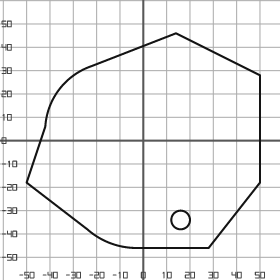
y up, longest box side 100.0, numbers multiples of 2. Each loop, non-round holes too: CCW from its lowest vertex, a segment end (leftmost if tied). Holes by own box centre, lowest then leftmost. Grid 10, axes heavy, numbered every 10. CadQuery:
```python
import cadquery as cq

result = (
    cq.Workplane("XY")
    .moveTo(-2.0, -46.0)
    .lineTo(28.0, -46.0)
    .lineTo(50.0, -18.0)
    .lineTo(50.0, 28.0)
    .lineTo(14.0, 46.0)
    .lineTo(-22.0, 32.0)
    .threePointArc((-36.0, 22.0), (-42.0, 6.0))
    .lineTo(-50.0, -18.0)
    .lineTo(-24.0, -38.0)
    .threePointArc((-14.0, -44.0), (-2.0, -46.0))
    .close()
    .moveTo(16.0, -34.0)
    .circle(4.0)
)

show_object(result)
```